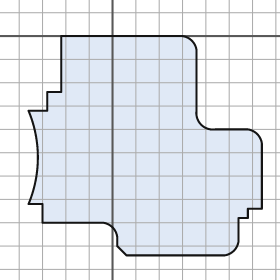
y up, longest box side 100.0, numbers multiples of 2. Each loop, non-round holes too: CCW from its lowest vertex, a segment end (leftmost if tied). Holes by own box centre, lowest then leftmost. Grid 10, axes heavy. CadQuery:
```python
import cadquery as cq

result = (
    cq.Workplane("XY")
    .moveTo(6.0, -94.0)
    .lineTo(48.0, -94.0)
    .threePointArc((52.0, -92.0), (54.0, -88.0))
    .lineTo(54.0, -78.0)
    .lineTo(58.0, -78.0)
    .lineTo(58.0, -74.0)
    .lineTo(64.0, -74.0)
    .lineTo(64.0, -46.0)
    .threePointArc((62.0, -42.0), (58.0, -40.0))
    .lineTo(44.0, -40.0)
    .threePointArc((38.0, -38.0), (36.0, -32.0))
    .lineTo(36.0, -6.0)
    .threePointArc((34.0, -2.0), (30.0, 0.0))
    .lineTo(-22.0, 0.0)
    .lineTo(-22.0, -24.0)
    .lineTo(-28.0, -24.0)
    .lineTo(-28.0, -32.0)
    .lineTo(-36.0, -32.0)
    .threePointArc((-32.0, -52.0), (-36.0, -72.0))
    .lineTo(-30.0, -72.0)
    .lineTo(-30.0, -80.0)
    .lineTo(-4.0, -80.0)
    .threePointArc((0.0, -82.0), (2.0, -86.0))
    .lineTo(2.0, -90.0)
    .close()
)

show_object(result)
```